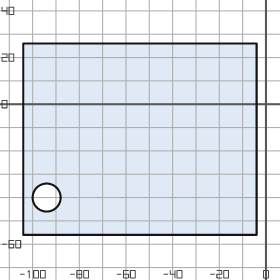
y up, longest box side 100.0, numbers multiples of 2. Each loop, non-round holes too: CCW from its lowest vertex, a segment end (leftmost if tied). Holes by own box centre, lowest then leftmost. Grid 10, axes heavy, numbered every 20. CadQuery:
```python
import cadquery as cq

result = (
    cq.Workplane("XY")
    .moveTo(-104.0, -56.0)
    .lineTo(-4.0, -56.0)
    .lineTo(-4.0, 26.0)
    .lineTo(-104.0, 26.0)
    .close()
    .moveTo(-94.0, -40.0)
    .circle(6.0)
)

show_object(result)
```